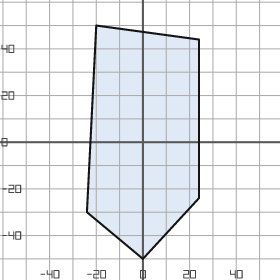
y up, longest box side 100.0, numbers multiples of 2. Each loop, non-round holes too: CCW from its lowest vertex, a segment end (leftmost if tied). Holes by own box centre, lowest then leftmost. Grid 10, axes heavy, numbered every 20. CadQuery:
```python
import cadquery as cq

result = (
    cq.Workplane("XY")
    .moveTo(0.0, -50.0)
    .lineTo(24.0, -24.0)
    .lineTo(24.0, 44.0)
    .lineTo(-20.0, 50.0)
    .lineTo(-24.0, -30.0)
    .close()
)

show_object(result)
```